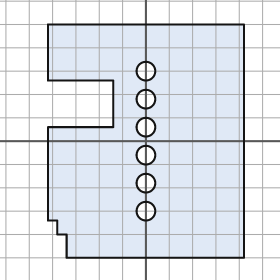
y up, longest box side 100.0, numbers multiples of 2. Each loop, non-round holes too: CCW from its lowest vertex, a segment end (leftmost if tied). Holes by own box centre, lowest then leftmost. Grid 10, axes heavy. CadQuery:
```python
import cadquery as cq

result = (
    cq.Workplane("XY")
    .moveTo(-34.0, -50.0)
    .lineTo(42.0, -50.0)
    .lineTo(42.0, 50.0)
    .lineTo(-42.0, 50.0)
    .lineTo(-42.0, 26.0)
    .lineTo(-14.0, 26.0)
    .lineTo(-14.0, 6.0)
    .lineTo(-42.0, 6.0)
    .lineTo(-42.0, -34.0)
    .lineTo(-38.0, -34.0)
    .lineTo(-38.0, -40.0)
    .lineTo(-34.0, -40.0)
    .close()
    .moveTo(0.0, -30.0)
    .circle(4.0)
    .moveTo(0.0, -18.0)
    .circle(4.0)
    .moveTo(0.0, -6.0)
    .circle(4.0)
    .moveTo(0.0, 6.0)
    .circle(4.0)
    .moveTo(0.0, 18.0)
    .circle(4.0)
    .moveTo(0.0, 30.0)
    .circle(4.0)
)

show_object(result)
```